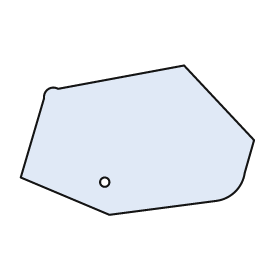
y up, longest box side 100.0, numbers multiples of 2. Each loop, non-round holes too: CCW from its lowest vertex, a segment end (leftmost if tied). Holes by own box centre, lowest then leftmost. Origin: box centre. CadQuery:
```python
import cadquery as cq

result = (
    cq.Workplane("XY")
    .moveTo(-12.0, -32.0)
    .lineTo(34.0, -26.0)
    .threePointArc((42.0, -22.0), (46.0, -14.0))
    .lineTo(50.0, 0.0)
    .lineTo(20.0, 32.0)
    .lineTo(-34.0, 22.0)
    .threePointArc((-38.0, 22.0), (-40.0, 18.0))
    .lineTo(-50.0, -16.0)
    .close()
    .moveTo(-14.0, -18.0)
    .circle(2.0)
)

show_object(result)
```